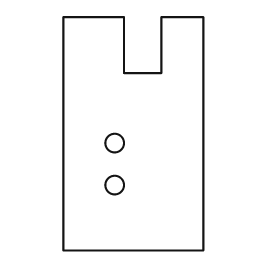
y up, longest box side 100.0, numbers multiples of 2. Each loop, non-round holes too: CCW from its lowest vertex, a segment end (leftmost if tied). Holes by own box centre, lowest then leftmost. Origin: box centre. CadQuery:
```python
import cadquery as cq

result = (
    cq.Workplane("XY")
    .moveTo(-30.0, -50.0)
    .lineTo(30.0, -50.0)
    .lineTo(30.0, 50.0)
    .lineTo(12.0, 50.0)
    .lineTo(12.0, 26.0)
    .lineTo(-4.0, 26.0)
    .lineTo(-4.0, 50.0)
    .lineTo(-30.0, 50.0)
    .close()
    .moveTo(-8.0, -22.0)
    .circle(4.0)
    .moveTo(-8.0, -4.0)
    .circle(4.0)
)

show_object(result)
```